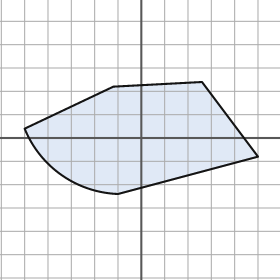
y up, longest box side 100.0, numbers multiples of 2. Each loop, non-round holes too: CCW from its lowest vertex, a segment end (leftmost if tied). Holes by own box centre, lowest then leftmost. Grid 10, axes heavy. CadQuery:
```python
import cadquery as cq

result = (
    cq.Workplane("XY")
    .moveTo(-10.0, -24.0)
    .lineTo(50.0, -8.0)
    .lineTo(26.0, 24.0)
    .lineTo(-12.0, 22.0)
    .lineTo(-50.0, 4.0)
    .threePointArc((-34.0, -16.0), (-10.0, -24.0))
    .close()
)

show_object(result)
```